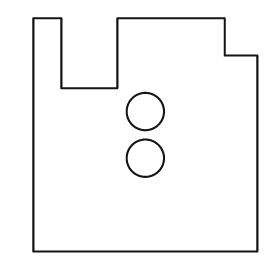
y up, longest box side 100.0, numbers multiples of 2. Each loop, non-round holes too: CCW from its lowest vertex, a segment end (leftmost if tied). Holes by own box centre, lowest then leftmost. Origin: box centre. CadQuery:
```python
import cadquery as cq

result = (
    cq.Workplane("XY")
    .moveTo(-48.0, -50.0)
    .lineTo(48.0, -50.0)
    .lineTo(48.0, 34.0)
    .lineTo(34.0, 34.0)
    .lineTo(34.0, 50.0)
    .lineTo(-12.0, 50.0)
    .lineTo(-12.0, 20.0)
    .lineTo(-36.0, 20.0)
    .lineTo(-36.0, 50.0)
    .lineTo(-48.0, 50.0)
    .close()
    .moveTo(0.0, -10.0)
    .circle(8.0)
    .moveTo(0.0, 10.0)
    .circle(8.0)
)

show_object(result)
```